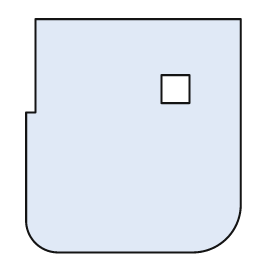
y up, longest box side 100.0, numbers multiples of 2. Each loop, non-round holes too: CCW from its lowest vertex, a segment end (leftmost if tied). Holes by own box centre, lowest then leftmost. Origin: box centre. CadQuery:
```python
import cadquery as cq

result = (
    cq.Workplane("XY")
    .moveTo(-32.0, -50.0)
    .lineTo(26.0, -50.0)
    .threePointArc((40.0, -44.0), (46.0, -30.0))
    .lineTo(46.0, 50.0)
    .lineTo(-42.0, 50.0)
    .lineTo(-42.0, 10.0)
    .lineTo(-46.0, 10.0)
    .lineTo(-46.0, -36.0)
    .threePointArc((-42.0, -46.0), (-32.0, -50.0))
    .close()
    .moveTo(12.0, 14.0)
    .lineTo(24.0, 14.0)
    .lineTo(24.0, 26.0)
    .lineTo(12.0, 26.0)
    .close()
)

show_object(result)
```